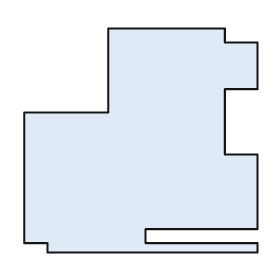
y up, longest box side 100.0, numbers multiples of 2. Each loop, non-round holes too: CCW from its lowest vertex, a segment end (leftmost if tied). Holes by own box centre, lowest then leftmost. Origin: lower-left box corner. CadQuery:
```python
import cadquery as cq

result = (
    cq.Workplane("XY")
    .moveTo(10.0, 0.0)
    .lineTo(100.0, 0.0)
    .lineTo(100.0, 4.0)
    .lineTo(52.0, 4.0)
    .lineTo(52.0, 10.0)
    .lineTo(100.0, 10.0)
    .lineTo(100.0, 42.0)
    .lineTo(86.0, 42.0)
    .lineTo(86.0, 70.0)
    .lineTo(100.0, 70.0)
    .lineTo(100.0, 90.0)
    .lineTo(86.0, 90.0)
    .lineTo(86.0, 96.0)
    .lineTo(36.0, 96.0)
    .lineTo(36.0, 60.0)
    .lineTo(0.0, 60.0)
    .lineTo(0.0, 4.0)
    .lineTo(10.0, 4.0)
    .close()
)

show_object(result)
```